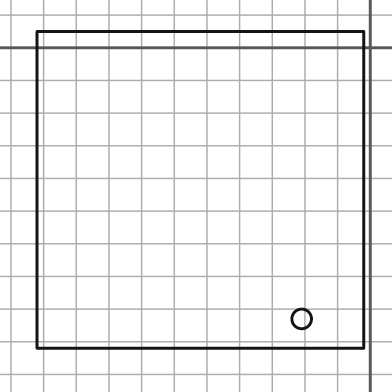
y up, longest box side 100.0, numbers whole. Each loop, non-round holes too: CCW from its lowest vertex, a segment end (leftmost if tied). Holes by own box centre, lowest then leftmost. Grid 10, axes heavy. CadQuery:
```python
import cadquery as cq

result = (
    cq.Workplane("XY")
    .moveTo(-102.0, -92.0)
    .lineTo(-2.0, -92.0)
    .lineTo(-2.0, 5.0)
    .lineTo(-102.0, 5.0)
    .close()
    .moveTo(-21.0, -83.0)
    .circle(3.0)
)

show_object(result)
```